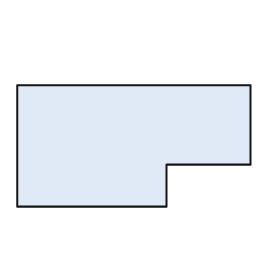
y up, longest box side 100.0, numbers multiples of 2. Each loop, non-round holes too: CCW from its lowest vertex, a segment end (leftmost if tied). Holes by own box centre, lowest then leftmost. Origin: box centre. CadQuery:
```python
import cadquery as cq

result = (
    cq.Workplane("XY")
    .moveTo(-50.0, -26.0)
    .lineTo(14.0, -26.0)
    .lineTo(14.0, -8.0)
    .lineTo(50.0, -8.0)
    .lineTo(50.0, 26.0)
    .lineTo(-50.0, 26.0)
    .close()
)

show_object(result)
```